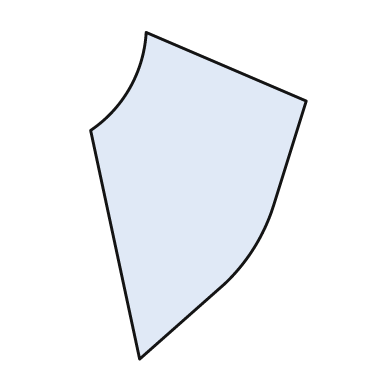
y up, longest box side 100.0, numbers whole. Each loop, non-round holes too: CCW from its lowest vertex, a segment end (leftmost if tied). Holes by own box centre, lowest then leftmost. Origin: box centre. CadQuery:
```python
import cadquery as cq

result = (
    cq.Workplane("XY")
    .moveTo(-18.0, -50.0)
    .lineTo(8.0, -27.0)
    .threePointArc((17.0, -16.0), (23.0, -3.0))
    .lineTo(33.0, 29.0)
    .lineTo(-16.0, 50.0)
    .threePointArc((-21.0, 33.0), (-33.0, 20.0))
    .close()
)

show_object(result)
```